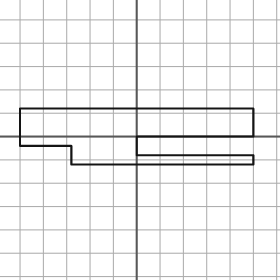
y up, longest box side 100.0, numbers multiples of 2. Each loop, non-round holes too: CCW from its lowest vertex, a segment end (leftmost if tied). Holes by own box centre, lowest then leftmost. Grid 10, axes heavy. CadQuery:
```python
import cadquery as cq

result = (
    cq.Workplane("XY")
    .moveTo(-28.0, -12.0)
    .lineTo(50.0, -12.0)
    .lineTo(50.0, -8.0)
    .lineTo(0.0, -8.0)
    .lineTo(0.0, 0.0)
    .lineTo(50.0, 0.0)
    .lineTo(50.0, 12.0)
    .lineTo(-50.0, 12.0)
    .lineTo(-50.0, -4.0)
    .lineTo(-28.0, -4.0)
    .close()
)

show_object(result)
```